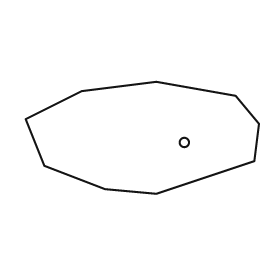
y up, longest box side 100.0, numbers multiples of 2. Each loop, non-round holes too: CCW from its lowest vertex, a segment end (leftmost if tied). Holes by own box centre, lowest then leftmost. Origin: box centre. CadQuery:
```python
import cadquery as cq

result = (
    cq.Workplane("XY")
    .moveTo(6.0, -24.0)
    .lineTo(48.0, -10.0)
    .lineTo(50.0, 6.0)
    .lineTo(40.0, 18.0)
    .lineTo(6.0, 24.0)
    .lineTo(-26.0, 20.0)
    .lineTo(-50.0, 8.0)
    .lineTo(-42.0, -12.0)
    .lineTo(-16.0, -22.0)
    .close()
    .moveTo(18.0, -2.0)
    .circle(2.0)
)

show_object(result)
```